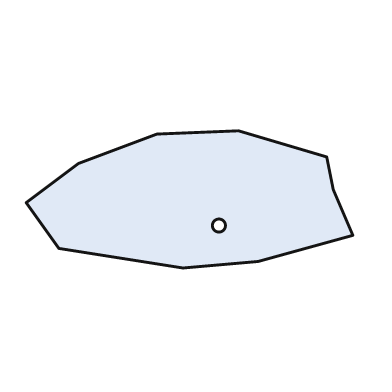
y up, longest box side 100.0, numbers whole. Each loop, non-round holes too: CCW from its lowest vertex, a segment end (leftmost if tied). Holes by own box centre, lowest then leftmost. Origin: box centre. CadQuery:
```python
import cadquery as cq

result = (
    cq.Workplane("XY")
    .moveTo(-2.0, -21.0)
    .lineTo(21.0, -19.0)
    .lineTo(50.0, -11.0)
    .lineTo(44.0, 3.0)
    .lineTo(42.0, 13.0)
    .lineTo(15.0, 21.0)
    .lineTo(-10.0, 20.0)
    .lineTo(-34.0, 11.0)
    .lineTo(-50.0, -1.0)
    .lineTo(-40.0, -15.0)
    .close()
    .moveTo(9.0, -8.0)
    .circle(2.0)
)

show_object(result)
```